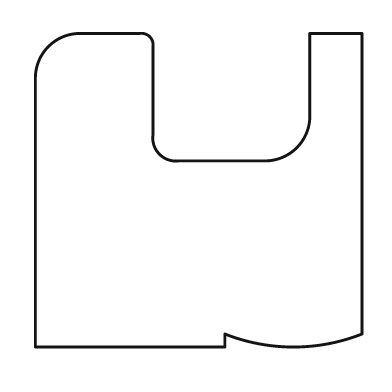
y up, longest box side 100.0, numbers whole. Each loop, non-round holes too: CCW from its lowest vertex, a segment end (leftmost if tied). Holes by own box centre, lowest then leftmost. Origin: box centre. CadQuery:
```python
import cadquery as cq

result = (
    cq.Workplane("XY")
    .moveTo(-50.0, -48.0)
    .lineTo(8.0, -48.0)
    .lineTo(8.0, -44.0)
    .threePointArc((29.0, -48.0), (50.0, -44.0))
    .lineTo(50.0, 48.0)
    .lineTo(34.0, 48.0)
    .lineTo(34.0, 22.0)
    .threePointArc((30.0, 13.0), (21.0, 9.0))
    .lineTo(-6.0, 9.0)
    .threePointArc((-12.0, 11.0), (-14.0, 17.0))
    .lineTo(-14.0, 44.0)
    .threePointArc((-15.0, 47.0), (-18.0, 48.0))
    .lineTo(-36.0, 48.0)
    .threePointArc((-46.0, 44.0), (-50.0, 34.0))
    .close()
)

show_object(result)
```